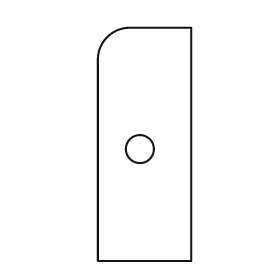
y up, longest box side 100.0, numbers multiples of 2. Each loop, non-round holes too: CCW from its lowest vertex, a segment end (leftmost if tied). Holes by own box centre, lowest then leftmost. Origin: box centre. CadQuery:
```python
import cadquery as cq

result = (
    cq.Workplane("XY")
    .moveTo(-20.0, -50.0)
    .lineTo(20.0, -50.0)
    .lineTo(20.0, 50.0)
    .lineTo(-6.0, 50.0)
    .threePointArc((-16.0, 46.0), (-20.0, 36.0))
    .close()
    .moveTo(-2.0, -2.0)
    .circle(6.0)
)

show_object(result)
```